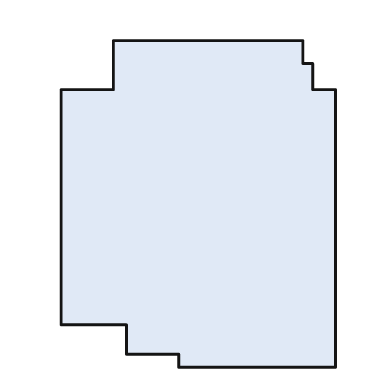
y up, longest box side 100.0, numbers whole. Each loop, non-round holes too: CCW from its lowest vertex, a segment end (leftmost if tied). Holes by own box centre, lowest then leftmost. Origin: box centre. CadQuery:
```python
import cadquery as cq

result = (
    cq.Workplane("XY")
    .moveTo(-6.0, -50.0)
    .lineTo(42.0, -50.0)
    .lineTo(42.0, 35.0)
    .lineTo(35.0, 35.0)
    .lineTo(35.0, 43.0)
    .lineTo(32.0, 43.0)
    .lineTo(32.0, 50.0)
    .lineTo(-26.0, 50.0)
    .lineTo(-26.0, 35.0)
    .lineTo(-42.0, 35.0)
    .lineTo(-42.0, -37.0)
    .lineTo(-22.0, -37.0)
    .lineTo(-22.0, -46.0)
    .lineTo(-6.0, -46.0)
    .close()
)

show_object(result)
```